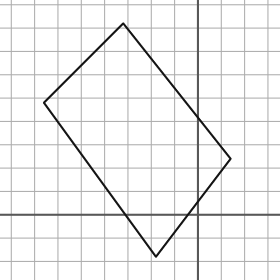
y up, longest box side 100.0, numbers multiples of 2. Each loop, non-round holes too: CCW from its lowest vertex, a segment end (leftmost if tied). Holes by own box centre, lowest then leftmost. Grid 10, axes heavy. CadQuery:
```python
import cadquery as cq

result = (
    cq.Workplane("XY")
    .moveTo(-18.0, -18.0)
    .lineTo(14.0, 24.0)
    .lineTo(-32.0, 82.0)
    .lineTo(-66.0, 48.0)
    .close()
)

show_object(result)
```